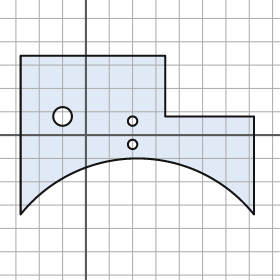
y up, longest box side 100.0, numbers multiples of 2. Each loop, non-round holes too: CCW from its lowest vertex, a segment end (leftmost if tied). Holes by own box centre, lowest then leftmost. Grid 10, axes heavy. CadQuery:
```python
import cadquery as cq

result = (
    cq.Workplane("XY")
    .moveTo(-28.0, -34.0)
    .threePointArc((22.0, -10.0), (72.0, -34.0))
    .lineTo(72.0, 8.0)
    .lineTo(34.0, 8.0)
    .lineTo(34.0, 34.0)
    .lineTo(-28.0, 34.0)
    .close()
    .moveTo(20.0, -4.0)
    .circle(2.0)
    .moveTo(20.0, 6.0)
    .circle(2.0)
    .moveTo(-10.0, 8.0)
    .circle(4.0)
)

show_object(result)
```